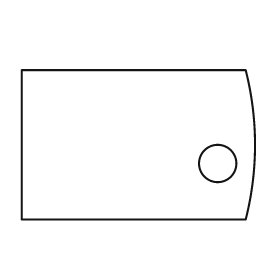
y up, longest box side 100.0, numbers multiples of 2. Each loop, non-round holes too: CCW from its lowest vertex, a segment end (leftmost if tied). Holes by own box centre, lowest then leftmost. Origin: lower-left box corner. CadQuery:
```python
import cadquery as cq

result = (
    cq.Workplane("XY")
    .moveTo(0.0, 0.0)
    .lineTo(96.0, 0.0)
    .threePointArc((100.0, 32.0), (96.0, 64.0))
    .lineTo(0.0, 64.0)
    .close()
    .moveTo(84.0, 24.0)
    .circle(8.0)
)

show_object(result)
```